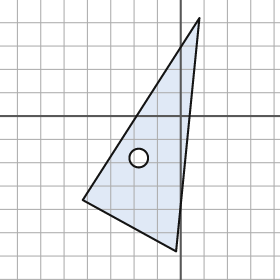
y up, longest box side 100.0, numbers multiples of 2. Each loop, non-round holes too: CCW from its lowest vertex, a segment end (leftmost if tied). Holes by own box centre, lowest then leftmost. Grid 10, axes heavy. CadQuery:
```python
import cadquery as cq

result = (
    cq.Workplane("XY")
    .moveTo(-2.0, -58.0)
    .lineTo(8.0, 42.0)
    .lineTo(-42.0, -36.0)
    .close()
    .moveTo(-18.0, -18.0)
    .circle(4.0)
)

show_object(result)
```